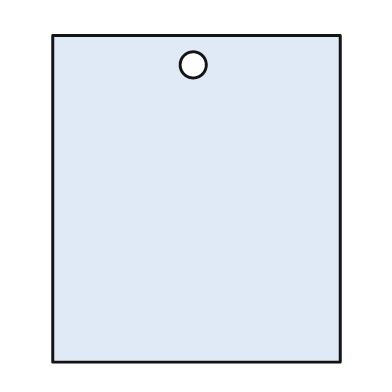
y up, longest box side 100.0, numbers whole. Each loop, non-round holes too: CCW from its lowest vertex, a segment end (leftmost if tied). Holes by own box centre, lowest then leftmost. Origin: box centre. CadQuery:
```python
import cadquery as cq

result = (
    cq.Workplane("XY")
    .moveTo(-44.0, -50.0)
    .lineTo(44.0, -50.0)
    .lineTo(44.0, 50.0)
    .lineTo(-44.0, 50.0)
    .close()
    .moveTo(-1.0, 41.0)
    .circle(4.0)
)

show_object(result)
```